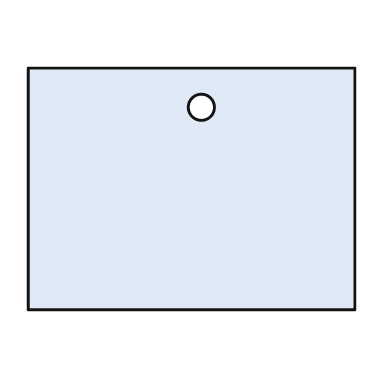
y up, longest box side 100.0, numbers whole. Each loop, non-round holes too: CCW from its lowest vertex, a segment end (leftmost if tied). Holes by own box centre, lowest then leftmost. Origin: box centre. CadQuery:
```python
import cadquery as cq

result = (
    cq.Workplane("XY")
    .moveTo(-50.0, -37.0)
    .lineTo(50.0, -37.0)
    .lineTo(50.0, 37.0)
    .lineTo(-50.0, 37.0)
    .close()
    .moveTo(3.0, 25.0)
    .circle(4.0)
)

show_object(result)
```